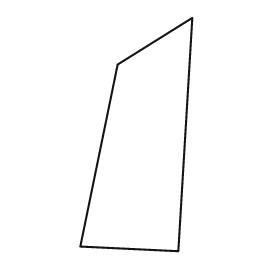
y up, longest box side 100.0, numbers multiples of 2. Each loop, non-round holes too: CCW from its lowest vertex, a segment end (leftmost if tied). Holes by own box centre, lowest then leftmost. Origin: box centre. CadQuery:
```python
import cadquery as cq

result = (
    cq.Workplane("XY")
    .moveTo(18.0, -50.0)
    .lineTo(24.0, 50.0)
    .lineTo(-8.0, 30.0)
    .lineTo(-24.0, -48.0)
    .close()
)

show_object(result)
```